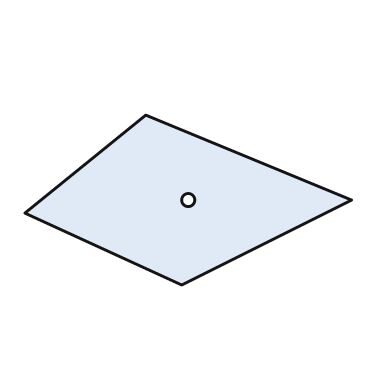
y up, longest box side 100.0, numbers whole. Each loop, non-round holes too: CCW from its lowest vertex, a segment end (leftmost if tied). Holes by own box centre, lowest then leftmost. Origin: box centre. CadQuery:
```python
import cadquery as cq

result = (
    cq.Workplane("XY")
    .moveTo(-2.0, -26.0)
    .lineTo(50.0, 0.0)
    .lineTo(-13.0, 26.0)
    .lineTo(-50.0, -4.0)
    .close()
    .moveTo(0.0, 0.0)
    .circle(2.0)
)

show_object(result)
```